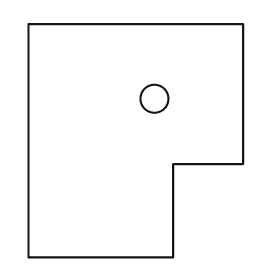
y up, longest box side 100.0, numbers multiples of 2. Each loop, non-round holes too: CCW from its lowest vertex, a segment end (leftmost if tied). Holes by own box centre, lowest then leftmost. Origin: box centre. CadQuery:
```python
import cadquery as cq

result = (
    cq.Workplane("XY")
    .moveTo(-46.0, -50.0)
    .lineTo(16.0, -50.0)
    .lineTo(16.0, -10.0)
    .lineTo(46.0, -10.0)
    .lineTo(46.0, 50.0)
    .lineTo(-46.0, 50.0)
    .close()
    .moveTo(8.0, 18.0)
    .circle(6.0)
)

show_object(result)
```